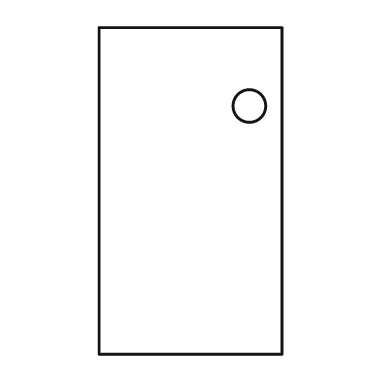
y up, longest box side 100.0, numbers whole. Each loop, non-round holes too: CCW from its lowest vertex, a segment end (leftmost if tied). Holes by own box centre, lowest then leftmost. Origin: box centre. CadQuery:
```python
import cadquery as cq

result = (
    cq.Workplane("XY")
    .moveTo(-28.0, -50.0)
    .lineTo(28.0, -50.0)
    .lineTo(28.0, 50.0)
    .lineTo(-28.0, 50.0)
    .close()
    .moveTo(18.0, 26.0)
    .circle(5.0)
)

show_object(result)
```